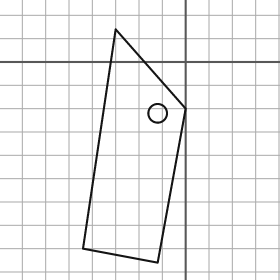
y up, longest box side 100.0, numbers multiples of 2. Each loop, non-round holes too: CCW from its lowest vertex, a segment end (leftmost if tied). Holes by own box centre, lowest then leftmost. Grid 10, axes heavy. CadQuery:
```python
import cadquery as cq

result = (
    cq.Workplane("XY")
    .moveTo(-12.0, -86.0)
    .lineTo(0.0, -20.0)
    .lineTo(-30.0, 14.0)
    .lineTo(-44.0, -80.0)
    .close()
    .moveTo(-12.0, -22.0)
    .circle(4.0)
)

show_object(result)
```